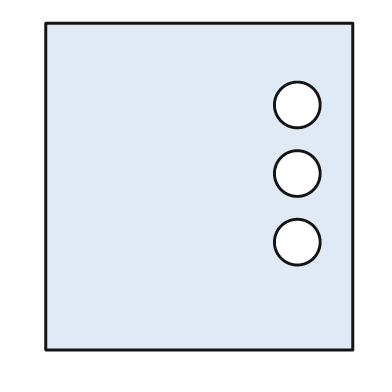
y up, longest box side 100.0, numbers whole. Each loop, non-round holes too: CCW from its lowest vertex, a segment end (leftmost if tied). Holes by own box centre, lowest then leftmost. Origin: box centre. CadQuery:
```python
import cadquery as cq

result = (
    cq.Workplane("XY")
    .moveTo(-47.0, -50.0)
    .lineTo(47.0, -50.0)
    .lineTo(47.0, 50.0)
    .lineTo(-47.0, 50.0)
    .close()
    .moveTo(30.0, -17.0)
    .circle(7.0)
    .moveTo(30.0, 4.0)
    .circle(7.0)
    .moveTo(30.0, 25.0)
    .circle(7.0)
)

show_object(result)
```